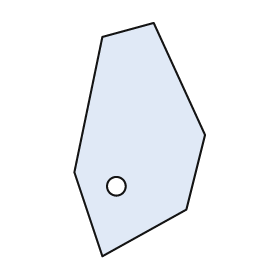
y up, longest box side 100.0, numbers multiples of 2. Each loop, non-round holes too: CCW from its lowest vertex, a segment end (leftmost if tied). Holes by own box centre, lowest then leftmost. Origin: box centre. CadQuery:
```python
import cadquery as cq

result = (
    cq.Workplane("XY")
    .moveTo(-16.0, -50.0)
    .lineTo(20.0, -30.0)
    .lineTo(28.0, 2.0)
    .lineTo(6.0, 50.0)
    .lineTo(-16.0, 44.0)
    .lineTo(-28.0, -14.0)
    .close()
    .moveTo(-10.0, -20.0)
    .circle(4.0)
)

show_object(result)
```